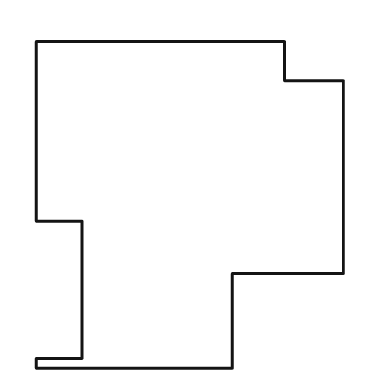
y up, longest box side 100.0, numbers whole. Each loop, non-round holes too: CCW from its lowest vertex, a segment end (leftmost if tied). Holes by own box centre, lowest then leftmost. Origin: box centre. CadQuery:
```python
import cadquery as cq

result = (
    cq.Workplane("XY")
    .moveTo(-47.0, -50.0)
    .lineTo(13.0, -50.0)
    .lineTo(13.0, -21.0)
    .lineTo(47.0, -21.0)
    .lineTo(47.0, 38.0)
    .lineTo(29.0, 38.0)
    .lineTo(29.0, 50.0)
    .lineTo(-47.0, 50.0)
    .lineTo(-47.0, -5.0)
    .lineTo(-33.0, -5.0)
    .lineTo(-33.0, -47.0)
    .lineTo(-47.0, -47.0)
    .close()
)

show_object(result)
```